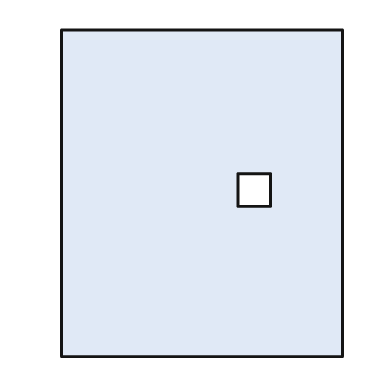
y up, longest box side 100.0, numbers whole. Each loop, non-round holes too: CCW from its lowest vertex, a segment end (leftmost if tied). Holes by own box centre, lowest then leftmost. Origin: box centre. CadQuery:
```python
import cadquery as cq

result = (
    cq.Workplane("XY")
    .moveTo(-43.0, -50.0)
    .lineTo(43.0, -50.0)
    .lineTo(43.0, 50.0)
    .lineTo(-43.0, 50.0)
    .close()
    .moveTo(11.0, -4.0)
    .lineTo(21.0, -4.0)
    .lineTo(21.0, 6.0)
    .lineTo(11.0, 6.0)
    .close()
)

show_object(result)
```